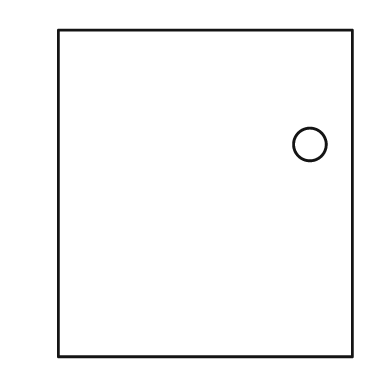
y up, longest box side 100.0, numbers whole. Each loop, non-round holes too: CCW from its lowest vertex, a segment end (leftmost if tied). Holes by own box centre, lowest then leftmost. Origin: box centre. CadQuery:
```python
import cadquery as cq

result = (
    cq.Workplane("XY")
    .moveTo(-45.0, -50.0)
    .lineTo(45.0, -50.0)
    .lineTo(45.0, 50.0)
    .lineTo(-45.0, 50.0)
    .close()
    .moveTo(32.0, 15.0)
    .circle(5.0)
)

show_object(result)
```